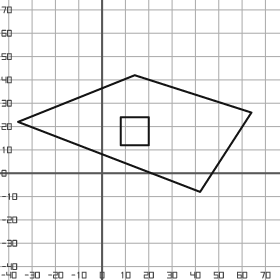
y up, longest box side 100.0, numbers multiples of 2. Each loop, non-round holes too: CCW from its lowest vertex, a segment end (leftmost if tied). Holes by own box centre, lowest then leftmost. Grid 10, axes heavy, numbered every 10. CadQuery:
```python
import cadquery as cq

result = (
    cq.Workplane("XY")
    .moveTo(42.0, -8.0)
    .lineTo(64.0, 26.0)
    .lineTo(14.0, 42.0)
    .lineTo(-36.0, 22.0)
    .close()
    .moveTo(8.0, 12.0)
    .lineTo(20.0, 12.0)
    .lineTo(20.0, 24.0)
    .lineTo(8.0, 24.0)
    .close()
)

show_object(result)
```